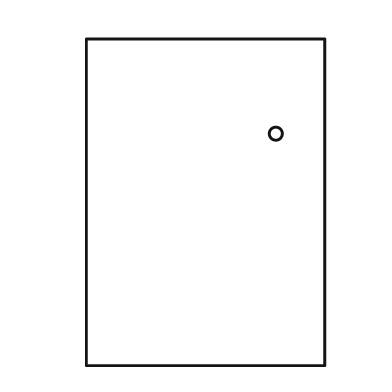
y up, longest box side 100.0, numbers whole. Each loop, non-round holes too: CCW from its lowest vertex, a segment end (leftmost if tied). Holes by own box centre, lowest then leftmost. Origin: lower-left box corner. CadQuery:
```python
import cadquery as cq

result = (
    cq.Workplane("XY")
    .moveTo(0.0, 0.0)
    .lineTo(73.0, 0.0)
    .lineTo(73.0, 100.0)
    .lineTo(0.0, 100.0)
    .close()
    .moveTo(58.0, 71.0)
    .circle(2.0)
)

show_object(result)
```